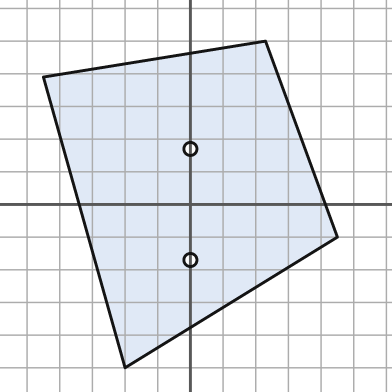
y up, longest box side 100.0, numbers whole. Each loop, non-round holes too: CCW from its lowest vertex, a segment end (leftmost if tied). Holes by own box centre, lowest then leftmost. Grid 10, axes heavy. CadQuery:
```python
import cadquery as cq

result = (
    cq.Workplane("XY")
    .moveTo(-20.0, -50.0)
    .lineTo(45.0, -10.0)
    .lineTo(23.0, 50.0)
    .lineTo(-45.0, 39.0)
    .close()
    .moveTo(0.0, -17.0)
    .circle(2.0)
    .moveTo(0.0, 17.0)
    .circle(2.0)
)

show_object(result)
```